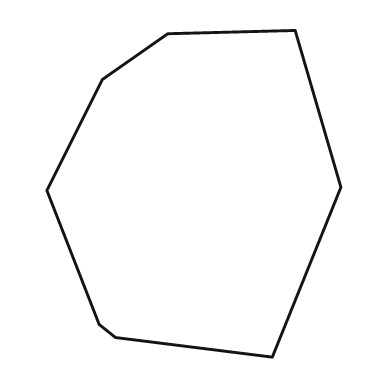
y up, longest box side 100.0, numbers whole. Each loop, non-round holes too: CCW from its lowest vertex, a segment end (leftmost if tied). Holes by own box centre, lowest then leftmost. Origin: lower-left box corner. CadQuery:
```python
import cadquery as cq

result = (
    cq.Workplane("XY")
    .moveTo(69.0, 0.0)
    .lineTo(90.0, 52.0)
    .lineTo(76.0, 100.0)
    .lineTo(37.0, 99.0)
    .lineTo(17.0, 85.0)
    .lineTo(0.0, 51.0)
    .lineTo(16.0, 10.0)
    .lineTo(21.0, 6.0)
    .close()
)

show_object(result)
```